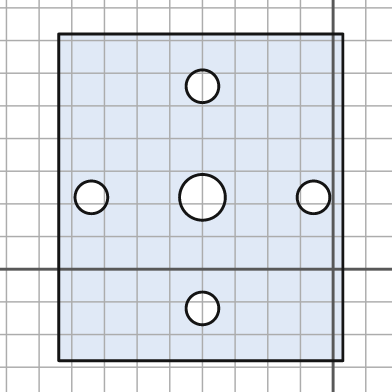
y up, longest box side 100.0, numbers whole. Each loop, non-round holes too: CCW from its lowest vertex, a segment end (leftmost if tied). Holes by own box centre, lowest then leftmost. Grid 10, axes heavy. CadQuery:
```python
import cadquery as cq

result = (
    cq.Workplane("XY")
    .moveTo(-84.0, -28.0)
    .lineTo(3.0, -28.0)
    .lineTo(3.0, 72.0)
    .lineTo(-84.0, 72.0)
    .close()
    .moveTo(-40.0, -12.0)
    .circle(5.0)
    .moveTo(-74.0, 22.0)
    .circle(5.0)
    .moveTo(-40.0, 22.0)
    .circle(7.0)
    .moveTo(-6.0, 22.0)
    .circle(5.0)
    .moveTo(-40.0, 56.0)
    .circle(5.0)
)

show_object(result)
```